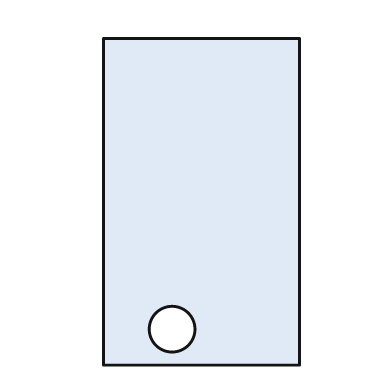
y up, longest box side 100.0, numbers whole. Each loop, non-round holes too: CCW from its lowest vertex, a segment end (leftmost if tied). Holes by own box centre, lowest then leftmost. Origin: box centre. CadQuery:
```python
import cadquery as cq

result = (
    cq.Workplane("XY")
    .moveTo(-30.0, -50.0)
    .lineTo(30.0, -50.0)
    .lineTo(30.0, 50.0)
    .lineTo(-30.0, 50.0)
    .close()
    .moveTo(-9.0, -39.0)
    .circle(7.0)
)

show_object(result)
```